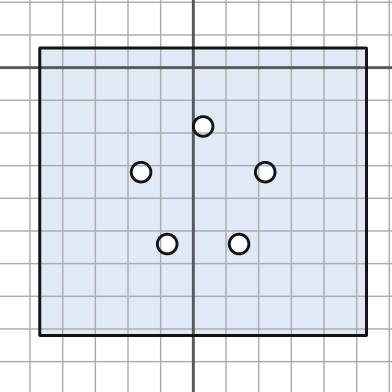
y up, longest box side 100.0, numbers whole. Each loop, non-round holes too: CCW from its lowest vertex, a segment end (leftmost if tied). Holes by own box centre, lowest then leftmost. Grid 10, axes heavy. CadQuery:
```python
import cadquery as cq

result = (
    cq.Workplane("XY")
    .moveTo(-47.0, -82.0)
    .lineTo(53.0, -82.0)
    .lineTo(53.0, 6.0)
    .lineTo(-47.0, 6.0)
    .close()
    .moveTo(-8.0, -54.0)
    .circle(3.0)
    .moveTo(14.0, -54.0)
    .circle(3.0)
    .moveTo(-16.0, -32.0)
    .circle(3.0)
    .moveTo(22.0, -32.0)
    .circle(3.0)
    .moveTo(3.0, -18.0)
    .circle(3.0)
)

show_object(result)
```